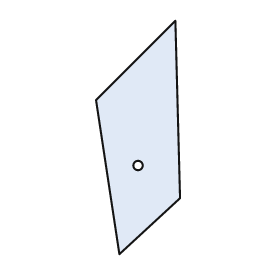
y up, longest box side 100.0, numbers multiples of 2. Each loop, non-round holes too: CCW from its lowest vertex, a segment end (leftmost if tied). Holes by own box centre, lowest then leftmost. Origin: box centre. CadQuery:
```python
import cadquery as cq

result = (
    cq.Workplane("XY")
    .moveTo(-8.0, -50.0)
    .lineTo(18.0, -26.0)
    .lineTo(16.0, 50.0)
    .lineTo(-18.0, 16.0)
    .close()
    .moveTo(0.0, -12.0)
    .circle(2.0)
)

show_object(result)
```